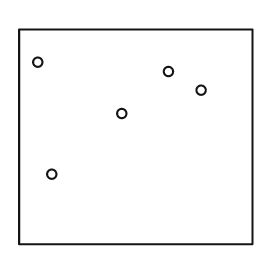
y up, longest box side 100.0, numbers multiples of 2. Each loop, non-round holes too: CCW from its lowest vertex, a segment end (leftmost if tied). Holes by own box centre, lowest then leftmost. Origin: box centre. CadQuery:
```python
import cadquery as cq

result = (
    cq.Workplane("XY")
    .moveTo(-50.0, -46.0)
    .lineTo(50.0, -46.0)
    .lineTo(50.0, 46.0)
    .lineTo(-50.0, 46.0)
    .close()
    .moveTo(-36.0, -16.0)
    .circle(2.0)
    .moveTo(-6.0, 10.0)
    .circle(2.0)
    .moveTo(28.0, 20.0)
    .circle(2.0)
    .moveTo(14.0, 28.0)
    .circle(2.0)
    .moveTo(-42.0, 32.0)
    .circle(2.0)
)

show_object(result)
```